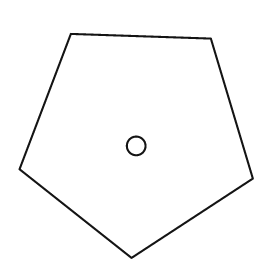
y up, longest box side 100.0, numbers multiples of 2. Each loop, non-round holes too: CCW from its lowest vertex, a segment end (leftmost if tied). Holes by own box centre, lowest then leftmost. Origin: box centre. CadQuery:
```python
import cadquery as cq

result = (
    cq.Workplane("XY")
    .moveTo(-2.0, -48.0)
    .lineTo(50.0, -14.0)
    .lineTo(32.0, 46.0)
    .lineTo(-28.0, 48.0)
    .lineTo(-50.0, -10.0)
    .close()
    .moveTo(0.0, 0.0)
    .circle(4.0)
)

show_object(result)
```